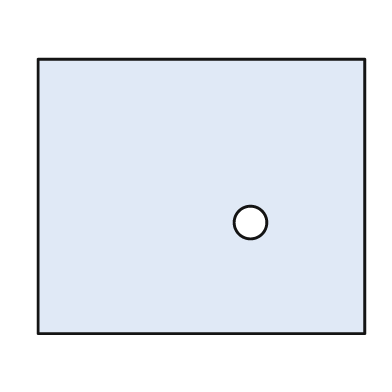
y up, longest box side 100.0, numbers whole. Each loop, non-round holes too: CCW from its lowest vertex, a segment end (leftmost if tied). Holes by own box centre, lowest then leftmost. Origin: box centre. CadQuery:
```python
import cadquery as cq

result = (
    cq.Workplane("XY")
    .moveTo(-50.0, -42.0)
    .lineTo(50.0, -42.0)
    .lineTo(50.0, 42.0)
    .lineTo(-50.0, 42.0)
    .close()
    .moveTo(15.0, -8.0)
    .circle(5.0)
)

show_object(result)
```